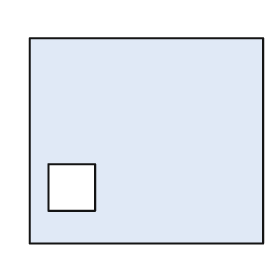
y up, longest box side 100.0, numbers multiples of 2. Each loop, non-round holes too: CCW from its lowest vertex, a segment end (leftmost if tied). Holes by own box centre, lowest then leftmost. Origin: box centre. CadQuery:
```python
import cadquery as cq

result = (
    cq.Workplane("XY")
    .moveTo(-50.0, -44.0)
    .lineTo(50.0, -44.0)
    .lineTo(50.0, 44.0)
    .lineTo(-50.0, 44.0)
    .close()
    .moveTo(-42.0, -30.0)
    .lineTo(-22.0, -30.0)
    .lineTo(-22.0, -10.0)
    .lineTo(-42.0, -10.0)
    .close()
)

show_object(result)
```